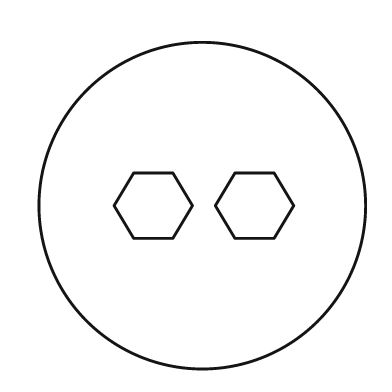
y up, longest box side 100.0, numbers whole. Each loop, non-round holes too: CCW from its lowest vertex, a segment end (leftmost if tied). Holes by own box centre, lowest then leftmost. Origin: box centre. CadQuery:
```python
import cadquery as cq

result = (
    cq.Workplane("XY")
    .moveTo(0.0, 0.0)
    .circle(50.0)
    .moveTo(-21.0, -10.0)
    .lineTo(-9.0, -10.0)
    .lineTo(-3.0, 0.0)
    .lineTo(-9.0, 10.0)
    .lineTo(-21.0, 10.0)
    .lineTo(-27.0, 0.0)
    .close()
    .moveTo(10.0, -10.0)
    .lineTo(22.0, -10.0)
    .lineTo(28.0, 0.0)
    .lineTo(22.0, 10.0)
    .lineTo(10.0, 10.0)
    .lineTo(4.0, 0.0)
    .close()
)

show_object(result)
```